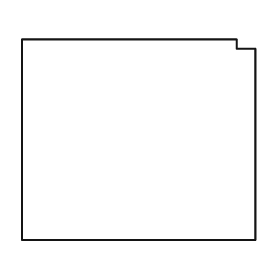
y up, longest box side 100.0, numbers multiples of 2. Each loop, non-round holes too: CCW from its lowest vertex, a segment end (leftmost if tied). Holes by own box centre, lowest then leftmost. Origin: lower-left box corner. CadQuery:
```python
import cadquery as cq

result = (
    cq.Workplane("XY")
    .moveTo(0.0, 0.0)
    .lineTo(100.0, 0.0)
    .lineTo(100.0, 82.0)
    .lineTo(92.0, 82.0)
    .lineTo(92.0, 86.0)
    .lineTo(0.0, 86.0)
    .close()
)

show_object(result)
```